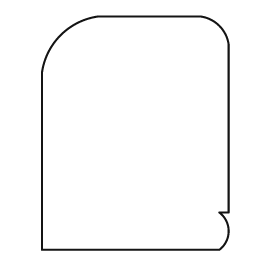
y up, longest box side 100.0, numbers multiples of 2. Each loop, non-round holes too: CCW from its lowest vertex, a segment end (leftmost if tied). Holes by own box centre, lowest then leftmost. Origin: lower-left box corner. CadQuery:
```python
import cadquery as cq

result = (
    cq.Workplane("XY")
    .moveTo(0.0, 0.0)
    .lineTo(76.0, 0.0)
    .threePointArc((80.0, 8.0), (76.0, 16.0))
    .lineTo(80.0, 16.0)
    .lineTo(80.0, 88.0)
    .threePointArc((76.0, 96.0), (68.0, 100.0))
    .lineTo(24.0, 100.0)
    .threePointArc((8.0, 92.0), (0.0, 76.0))
    .close()
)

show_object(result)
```